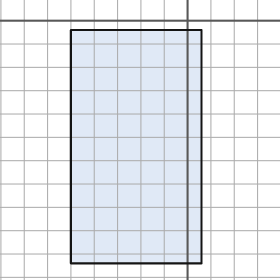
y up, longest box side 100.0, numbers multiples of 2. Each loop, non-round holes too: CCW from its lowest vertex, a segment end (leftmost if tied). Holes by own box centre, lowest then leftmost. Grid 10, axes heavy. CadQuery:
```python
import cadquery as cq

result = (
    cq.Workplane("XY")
    .moveTo(-50.0, -104.0)
    .lineTo(6.0, -104.0)
    .lineTo(6.0, -4.0)
    .lineTo(-50.0, -4.0)
    .close()
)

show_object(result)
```